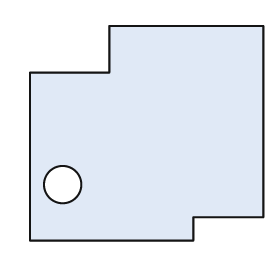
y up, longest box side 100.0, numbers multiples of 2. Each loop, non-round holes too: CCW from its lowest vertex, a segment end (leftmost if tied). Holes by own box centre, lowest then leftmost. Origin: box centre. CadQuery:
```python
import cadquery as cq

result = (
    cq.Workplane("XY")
    .moveTo(-50.0, -46.0)
    .lineTo(20.0, -46.0)
    .lineTo(20.0, -36.0)
    .lineTo(50.0, -36.0)
    .lineTo(50.0, 46.0)
    .lineTo(-16.0, 46.0)
    .lineTo(-16.0, 26.0)
    .lineTo(-50.0, 26.0)
    .close()
    .moveTo(-36.0, -22.0)
    .circle(8.0)
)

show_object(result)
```